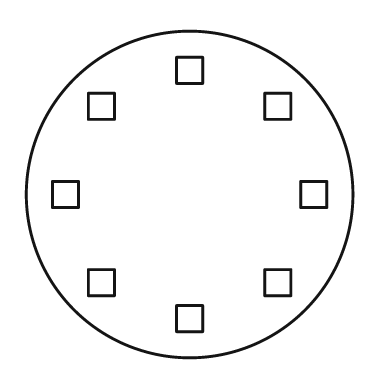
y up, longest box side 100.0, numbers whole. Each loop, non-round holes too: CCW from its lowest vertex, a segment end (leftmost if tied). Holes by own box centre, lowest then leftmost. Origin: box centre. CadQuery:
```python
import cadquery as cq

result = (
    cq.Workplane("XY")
    .moveTo(0.0, 0.0)
    .circle(50.0)
    .moveTo(-4.0, -42.0)
    .lineTo(4.0, -42.0)
    .lineTo(4.0, -34.0)
    .lineTo(-4.0, -34.0)
    .close()
    .moveTo(-31.0, -31.0)
    .lineTo(-23.0, -31.0)
    .lineTo(-23.0, -23.0)
    .lineTo(-31.0, -23.0)
    .close()
    .moveTo(23.0, -31.0)
    .lineTo(31.0, -31.0)
    .lineTo(31.0, -23.0)
    .lineTo(23.0, -23.0)
    .close()
    .moveTo(-42.0, -4.0)
    .lineTo(-34.0, -4.0)
    .lineTo(-34.0, 4.0)
    .lineTo(-42.0, 4.0)
    .close()
    .moveTo(34.0, -4.0)
    .lineTo(42.0, -4.0)
    .lineTo(42.0, 4.0)
    .lineTo(34.0, 4.0)
    .close()
    .moveTo(-31.0, 23.0)
    .lineTo(-23.0, 23.0)
    .lineTo(-23.0, 31.0)
    .lineTo(-31.0, 31.0)
    .close()
    .moveTo(23.0, 23.0)
    .lineTo(31.0, 23.0)
    .lineTo(31.0, 31.0)
    .lineTo(23.0, 31.0)
    .close()
    .moveTo(-4.0, 34.0)
    .lineTo(4.0, 34.0)
    .lineTo(4.0, 42.0)
    .lineTo(-4.0, 42.0)
    .close()
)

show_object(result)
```